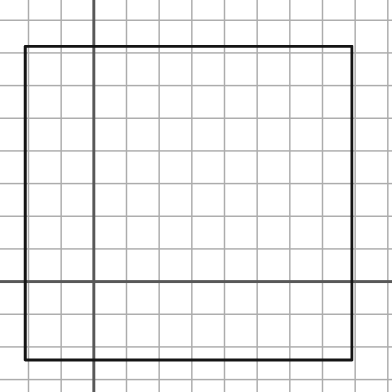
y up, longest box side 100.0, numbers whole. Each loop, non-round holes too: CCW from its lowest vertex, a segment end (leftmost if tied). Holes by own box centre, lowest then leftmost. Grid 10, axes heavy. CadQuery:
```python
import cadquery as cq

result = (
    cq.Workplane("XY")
    .moveTo(-21.0, -24.0)
    .lineTo(79.0, -24.0)
    .lineTo(79.0, 72.0)
    .lineTo(-21.0, 72.0)
    .close()
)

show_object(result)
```